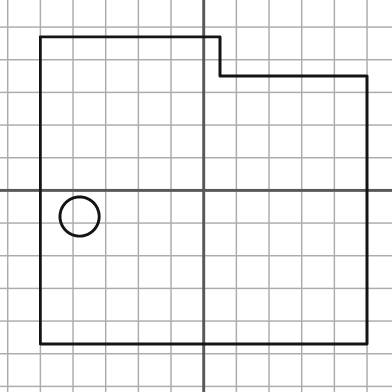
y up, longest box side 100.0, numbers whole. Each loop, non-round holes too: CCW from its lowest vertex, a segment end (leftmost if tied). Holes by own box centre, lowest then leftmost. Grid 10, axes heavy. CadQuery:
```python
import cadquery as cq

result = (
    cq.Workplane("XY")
    .moveTo(-50.0, -47.0)
    .lineTo(50.0, -47.0)
    .lineTo(50.0, 35.0)
    .lineTo(5.0, 35.0)
    .lineTo(5.0, 47.0)
    .lineTo(-50.0, 47.0)
    .close()
    .moveTo(-38.0, -8.0)
    .circle(6.0)
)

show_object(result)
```